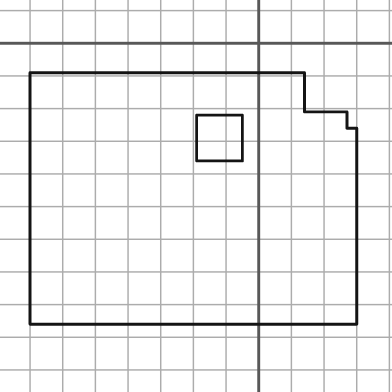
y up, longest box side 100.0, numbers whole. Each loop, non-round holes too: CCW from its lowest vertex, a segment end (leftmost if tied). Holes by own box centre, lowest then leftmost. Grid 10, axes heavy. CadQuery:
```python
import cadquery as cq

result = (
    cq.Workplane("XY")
    .moveTo(-70.0, -86.0)
    .lineTo(30.0, -86.0)
    .lineTo(30.0, -26.0)
    .lineTo(27.0, -26.0)
    .lineTo(27.0, -21.0)
    .lineTo(14.0, -21.0)
    .lineTo(14.0, -9.0)
    .lineTo(-70.0, -9.0)
    .close()
    .moveTo(-19.0, -36.0)
    .lineTo(-5.0, -36.0)
    .lineTo(-5.0, -22.0)
    .lineTo(-19.0, -22.0)
    .close()
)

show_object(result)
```